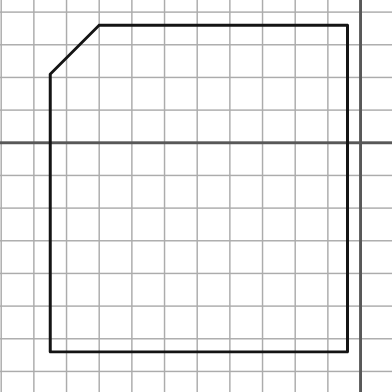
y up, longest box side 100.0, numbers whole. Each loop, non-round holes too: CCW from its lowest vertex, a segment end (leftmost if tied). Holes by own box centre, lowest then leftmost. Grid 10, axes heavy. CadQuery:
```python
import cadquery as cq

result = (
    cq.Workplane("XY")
    .moveTo(-95.0, -64.0)
    .lineTo(-4.0, -64.0)
    .lineTo(-4.0, 36.0)
    .lineTo(-80.0, 36.0)
    .lineTo(-95.0, 21.0)
    .close()
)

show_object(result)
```